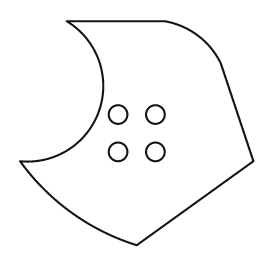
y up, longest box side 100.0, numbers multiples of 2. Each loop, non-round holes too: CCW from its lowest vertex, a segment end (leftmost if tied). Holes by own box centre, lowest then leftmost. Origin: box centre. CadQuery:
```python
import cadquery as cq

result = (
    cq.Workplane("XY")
    .moveTo(0.0, -48.0)
    .lineTo(50.0, -12.0)
    .lineTo(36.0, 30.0)
    .threePointArc((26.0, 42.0), (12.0, 48.0))
    .lineTo(-30.0, 48.0)
    .threePointArc((-16.0, 10.0), (-50.0, -12.0))
    .threePointArc((-28.0, -34.0), (0.0, -48.0))
    .close()
    .moveTo(-8.0, -8.0)
    .circle(4.0)
    .moveTo(8.0, -8.0)
    .circle(4.0)
    .moveTo(-8.0, 8.0)
    .circle(4.0)
    .moveTo(8.0, 8.0)
    .circle(4.0)
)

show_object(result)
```